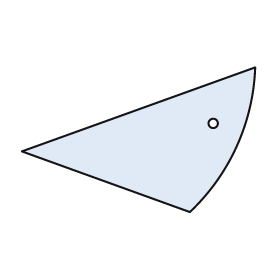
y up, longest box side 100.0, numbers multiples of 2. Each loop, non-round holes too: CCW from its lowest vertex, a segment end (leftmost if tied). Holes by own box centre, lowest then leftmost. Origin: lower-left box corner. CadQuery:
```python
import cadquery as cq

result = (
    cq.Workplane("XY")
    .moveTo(72.0, 0.0)
    .threePointArc((92.0, 28.0), (100.0, 62.0))
    .lineTo(0.0, 26.0)
    .close()
    .moveTo(82.0, 38.0)
    .circle(2.0)
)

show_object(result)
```